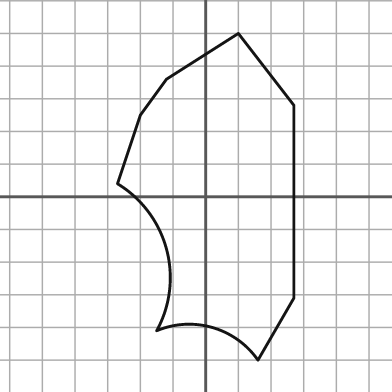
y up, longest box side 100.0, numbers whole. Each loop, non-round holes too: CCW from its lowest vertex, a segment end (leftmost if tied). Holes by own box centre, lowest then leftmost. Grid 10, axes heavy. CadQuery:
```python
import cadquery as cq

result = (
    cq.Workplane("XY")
    .moveTo(16.0, -50.0)
    .lineTo(27.0, -31.0)
    .lineTo(27.0, 28.0)
    .lineTo(10.0, 50.0)
    .lineTo(-12.0, 36.0)
    .lineTo(-20.0, 25.0)
    .lineTo(-27.0, 4.0)
    .threePointArc((-12.0, -16.0), (-15.0, -41.0))
    .threePointArc((2.0, -40.0), (16.0, -50.0))
    .close()
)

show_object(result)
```